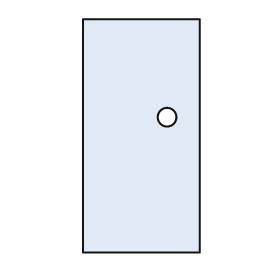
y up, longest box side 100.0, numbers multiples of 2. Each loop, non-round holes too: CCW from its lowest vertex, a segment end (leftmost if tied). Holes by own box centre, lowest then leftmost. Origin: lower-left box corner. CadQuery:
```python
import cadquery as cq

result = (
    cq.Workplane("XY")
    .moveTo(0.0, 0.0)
    .lineTo(50.0, 0.0)
    .lineTo(50.0, 100.0)
    .lineTo(0.0, 100.0)
    .close()
    .moveTo(36.0, 58.0)
    .circle(4.0)
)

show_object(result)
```